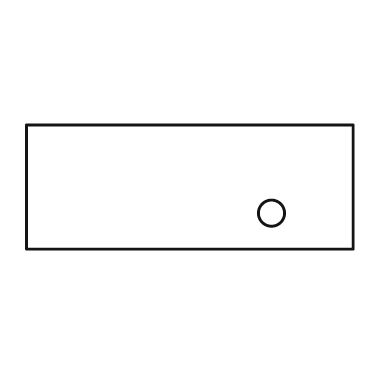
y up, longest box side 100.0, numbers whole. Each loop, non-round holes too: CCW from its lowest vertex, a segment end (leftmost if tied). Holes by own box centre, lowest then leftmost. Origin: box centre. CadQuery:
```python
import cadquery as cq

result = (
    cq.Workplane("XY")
    .moveTo(-50.0, -19.0)
    .lineTo(50.0, -19.0)
    .lineTo(50.0, 19.0)
    .lineTo(-50.0, 19.0)
    .close()
    .moveTo(25.0, -8.0)
    .circle(4.0)
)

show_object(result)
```